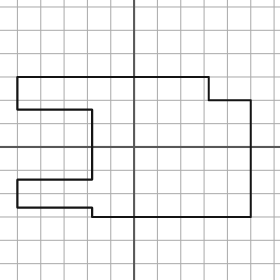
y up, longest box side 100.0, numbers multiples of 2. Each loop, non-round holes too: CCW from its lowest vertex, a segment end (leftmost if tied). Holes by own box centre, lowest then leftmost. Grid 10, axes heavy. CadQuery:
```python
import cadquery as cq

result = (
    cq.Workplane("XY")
    .moveTo(-18.0, -30.0)
    .lineTo(50.0, -30.0)
    .lineTo(50.0, 20.0)
    .lineTo(32.0, 20.0)
    .lineTo(32.0, 30.0)
    .lineTo(-50.0, 30.0)
    .lineTo(-50.0, 16.0)
    .lineTo(-18.0, 16.0)
    .lineTo(-18.0, -14.0)
    .lineTo(-50.0, -14.0)
    .lineTo(-50.0, -26.0)
    .lineTo(-18.0, -26.0)
    .close()
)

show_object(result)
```